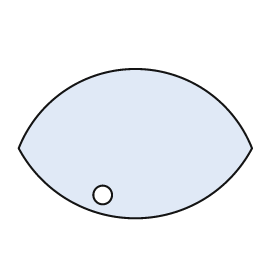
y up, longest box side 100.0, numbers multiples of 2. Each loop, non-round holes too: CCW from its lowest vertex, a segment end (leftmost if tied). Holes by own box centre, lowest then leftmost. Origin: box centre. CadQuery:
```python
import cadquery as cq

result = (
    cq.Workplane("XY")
    .moveTo(-50.0, -2.0)
    .threePointArc((0.0, -32.0), (50.0, -2.0))
    .threePointArc((0.0, 32.0), (-50.0, -2.0))
    .close()
    .moveTo(-14.0, -22.0)
    .circle(4.0)
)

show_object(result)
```